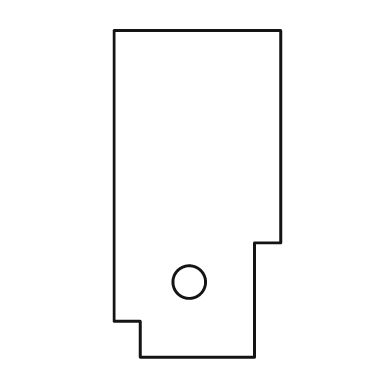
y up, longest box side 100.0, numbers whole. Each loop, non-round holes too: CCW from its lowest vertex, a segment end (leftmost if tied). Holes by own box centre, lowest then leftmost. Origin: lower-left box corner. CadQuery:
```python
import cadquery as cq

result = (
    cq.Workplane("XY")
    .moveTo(8.0, 0.0)
    .lineTo(43.0, 0.0)
    .lineTo(43.0, 35.0)
    .lineTo(51.0, 35.0)
    .lineTo(51.0, 100.0)
    .lineTo(0.0, 100.0)
    .lineTo(0.0, 11.0)
    .lineTo(8.0, 11.0)
    .close()
    .moveTo(23.0, 23.0)
    .circle(5.0)
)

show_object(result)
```